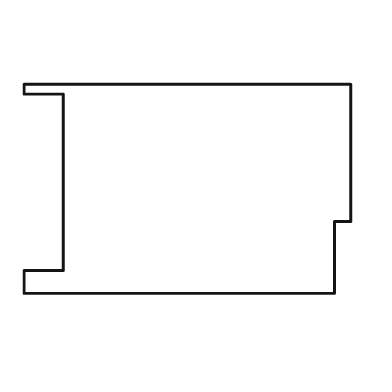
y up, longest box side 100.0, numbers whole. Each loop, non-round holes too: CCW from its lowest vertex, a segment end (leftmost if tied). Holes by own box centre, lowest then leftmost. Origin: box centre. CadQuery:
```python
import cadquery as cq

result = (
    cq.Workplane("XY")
    .moveTo(-50.0, -32.0)
    .lineTo(45.0, -32.0)
    .lineTo(45.0, -10.0)
    .lineTo(50.0, -10.0)
    .lineTo(50.0, 32.0)
    .lineTo(-50.0, 32.0)
    .lineTo(-50.0, 29.0)
    .lineTo(-38.0, 29.0)
    .lineTo(-38.0, -25.0)
    .lineTo(-50.0, -25.0)
    .close()
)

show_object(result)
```